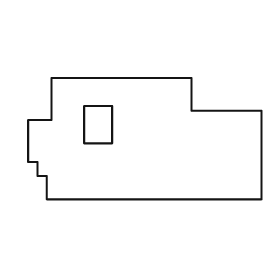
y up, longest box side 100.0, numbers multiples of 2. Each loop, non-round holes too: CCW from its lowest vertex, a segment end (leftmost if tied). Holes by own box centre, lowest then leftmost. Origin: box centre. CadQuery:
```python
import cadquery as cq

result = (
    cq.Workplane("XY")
    .moveTo(-42.0, -26.0)
    .lineTo(50.0, -26.0)
    .lineTo(50.0, 12.0)
    .lineTo(20.0, 12.0)
    .lineTo(20.0, 26.0)
    .lineTo(-40.0, 26.0)
    .lineTo(-40.0, 8.0)
    .lineTo(-50.0, 8.0)
    .lineTo(-50.0, -10.0)
    .lineTo(-46.0, -10.0)
    .lineTo(-46.0, -16.0)
    .lineTo(-42.0, -16.0)
    .close()
    .moveTo(-26.0, -2.0)
    .lineTo(-14.0, -2.0)
    .lineTo(-14.0, 14.0)
    .lineTo(-26.0, 14.0)
    .close()
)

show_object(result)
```